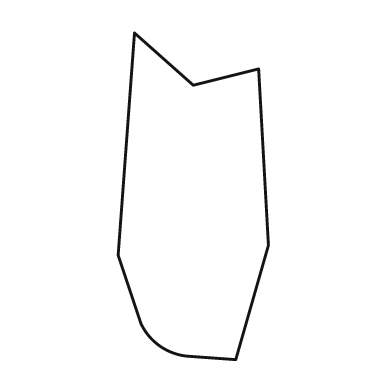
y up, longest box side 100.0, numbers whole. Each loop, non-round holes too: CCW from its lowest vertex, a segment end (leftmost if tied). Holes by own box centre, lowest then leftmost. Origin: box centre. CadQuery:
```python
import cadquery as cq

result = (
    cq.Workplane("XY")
    .moveTo(13.0, -50.0)
    .lineTo(23.0, -15.0)
    .lineTo(20.0, 39.0)
    .lineTo(0.0, 34.0)
    .lineTo(-18.0, 50.0)
    .lineTo(-23.0, -18.0)
    .lineTo(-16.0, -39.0)
    .threePointArc((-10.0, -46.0), (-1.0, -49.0))
    .close()
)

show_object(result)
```